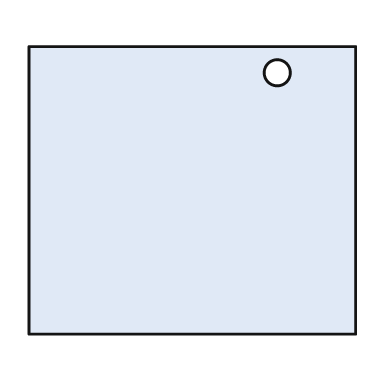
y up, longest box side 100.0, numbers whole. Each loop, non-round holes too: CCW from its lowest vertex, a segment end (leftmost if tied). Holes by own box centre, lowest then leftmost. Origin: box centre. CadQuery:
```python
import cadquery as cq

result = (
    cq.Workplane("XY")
    .moveTo(-50.0, -44.0)
    .lineTo(50.0, -44.0)
    .lineTo(50.0, 44.0)
    .lineTo(-50.0, 44.0)
    .close()
    .moveTo(26.0, 36.0)
    .circle(4.0)
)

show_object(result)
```